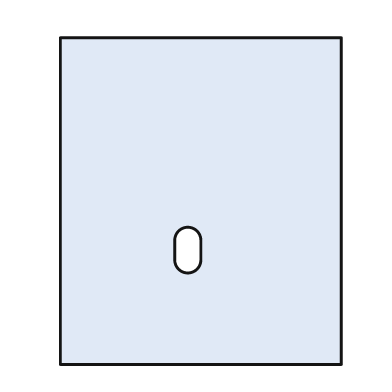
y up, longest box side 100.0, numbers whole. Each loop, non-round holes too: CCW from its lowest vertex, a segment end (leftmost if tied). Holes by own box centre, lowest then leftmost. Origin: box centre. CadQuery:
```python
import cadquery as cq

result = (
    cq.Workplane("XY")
    .moveTo(-43.0, -50.0)
    .lineTo(43.0, -50.0)
    .lineTo(43.0, 50.0)
    .lineTo(-43.0, 50.0)
    .close()
    .moveTo(-8.0, -18.0)
    .threePointArc((-4.0, -22.0), (0.0, -18.0))
    .lineTo(0.0, -12.0)
    .threePointArc((-4.0, -8.0), (-8.0, -12.0))
    .close()
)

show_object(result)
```